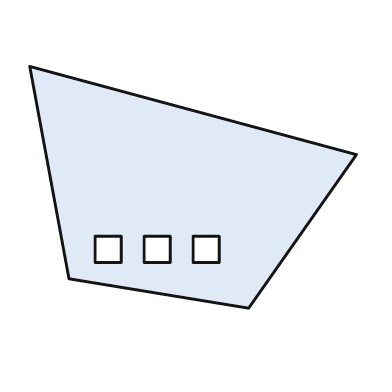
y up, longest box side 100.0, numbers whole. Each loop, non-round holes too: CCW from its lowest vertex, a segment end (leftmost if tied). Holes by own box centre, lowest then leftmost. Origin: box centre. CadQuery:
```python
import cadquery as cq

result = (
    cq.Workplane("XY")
    .moveTo(17.0, -37.0)
    .lineTo(50.0, 10.0)
    .lineTo(-50.0, 37.0)
    .lineTo(-38.0, -28.0)
    .close()
    .moveTo(-30.0, -23.0)
    .lineTo(-22.0, -23.0)
    .lineTo(-22.0, -15.0)
    .lineTo(-30.0, -15.0)
    .close()
    .moveTo(-15.0, -23.0)
    .lineTo(-7.0, -23.0)
    .lineTo(-7.0, -15.0)
    .lineTo(-15.0, -15.0)
    .close()
    .moveTo(0.0, -23.0)
    .lineTo(8.0, -23.0)
    .lineTo(8.0, -15.0)
    .lineTo(0.0, -15.0)
    .close()
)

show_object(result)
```